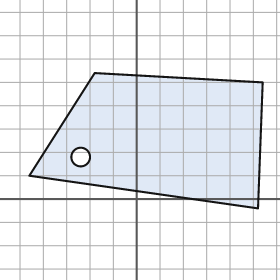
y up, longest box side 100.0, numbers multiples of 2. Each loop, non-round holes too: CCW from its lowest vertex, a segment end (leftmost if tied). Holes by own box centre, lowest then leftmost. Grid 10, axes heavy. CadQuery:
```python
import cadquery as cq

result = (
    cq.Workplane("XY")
    .moveTo(52.0, -4.0)
    .lineTo(54.0, 50.0)
    .lineTo(-18.0, 54.0)
    .lineTo(-46.0, 10.0)
    .close()
    .moveTo(-24.0, 18.0)
    .circle(4.0)
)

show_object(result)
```